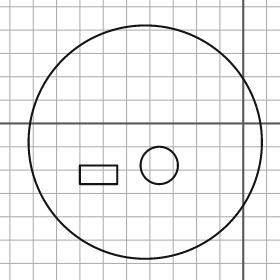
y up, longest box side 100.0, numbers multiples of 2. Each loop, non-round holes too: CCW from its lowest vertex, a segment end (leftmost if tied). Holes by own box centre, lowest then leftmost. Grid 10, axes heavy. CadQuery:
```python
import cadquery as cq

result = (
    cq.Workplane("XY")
    .moveTo(-42.0, -8.0)
    .circle(50.0)
    .moveTo(-70.0, -26.0)
    .lineTo(-54.0, -26.0)
    .lineTo(-54.0, -18.0)
    .lineTo(-70.0, -18.0)
    .close()
    .moveTo(-36.0, -18.0)
    .circle(8.0)
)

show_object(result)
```